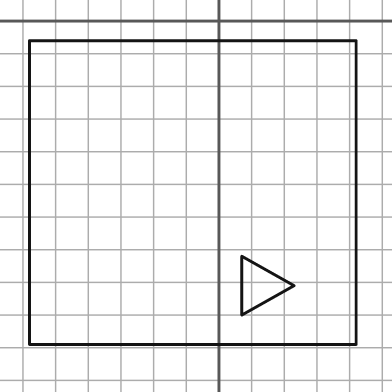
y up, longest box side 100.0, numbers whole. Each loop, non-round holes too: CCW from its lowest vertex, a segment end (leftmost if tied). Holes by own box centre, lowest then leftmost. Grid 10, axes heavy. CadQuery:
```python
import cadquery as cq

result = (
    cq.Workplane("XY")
    .moveTo(-58.0, -99.0)
    .lineTo(42.0, -99.0)
    .lineTo(42.0, -6.0)
    .lineTo(-58.0, -6.0)
    .close()
    .moveTo(7.0, -90.0)
    .lineTo(23.0, -81.0)
    .lineTo(7.0, -72.0)
    .close()
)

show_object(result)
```